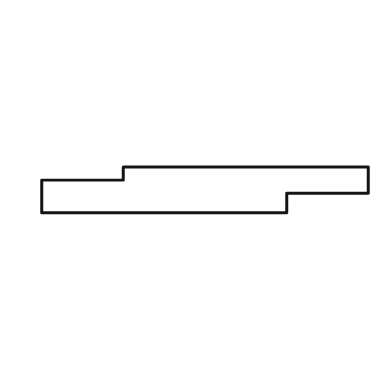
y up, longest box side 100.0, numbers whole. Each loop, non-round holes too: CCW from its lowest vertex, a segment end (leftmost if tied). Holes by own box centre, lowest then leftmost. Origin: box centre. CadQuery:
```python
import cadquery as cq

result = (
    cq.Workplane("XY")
    .moveTo(-50.0, -7.0)
    .lineTo(25.0, -7.0)
    .lineTo(25.0, -1.0)
    .lineTo(50.0, -1.0)
    .lineTo(50.0, 7.0)
    .lineTo(-25.0, 7.0)
    .lineTo(-25.0, 3.0)
    .lineTo(-50.0, 3.0)
    .close()
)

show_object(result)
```